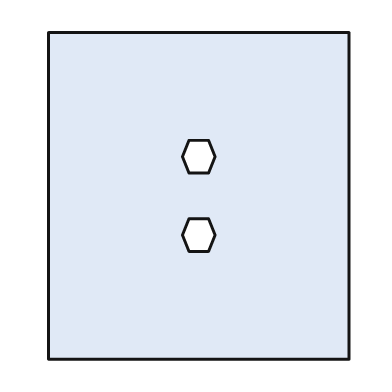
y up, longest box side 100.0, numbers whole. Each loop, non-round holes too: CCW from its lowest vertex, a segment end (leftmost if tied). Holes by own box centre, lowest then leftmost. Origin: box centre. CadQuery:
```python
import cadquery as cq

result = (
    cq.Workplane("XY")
    .moveTo(-46.0, -50.0)
    .lineTo(46.0, -50.0)
    .lineTo(46.0, 50.0)
    .lineTo(-46.0, 50.0)
    .close()
    .moveTo(-3.0, -17.0)
    .lineTo(3.0, -17.0)
    .lineTo(5.0, -12.0)
    .lineTo(3.0, -7.0)
    .lineTo(-3.0, -7.0)
    .lineTo(-5.0, -12.0)
    .close()
    .moveTo(-3.0, 7.0)
    .lineTo(3.0, 7.0)
    .lineTo(5.0, 12.0)
    .lineTo(3.0, 17.0)
    .lineTo(-3.0, 17.0)
    .lineTo(-5.0, 12.0)
    .close()
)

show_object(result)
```